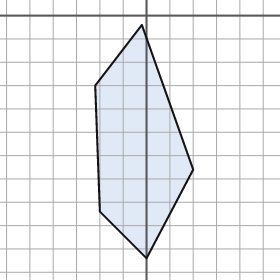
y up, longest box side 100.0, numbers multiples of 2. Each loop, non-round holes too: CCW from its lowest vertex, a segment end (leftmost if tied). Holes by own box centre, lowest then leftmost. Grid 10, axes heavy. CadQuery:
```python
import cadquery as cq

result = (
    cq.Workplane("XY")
    .moveTo(0.0, -104.0)
    .lineTo(20.0, -66.0)
    .lineTo(-2.0, -4.0)
    .lineTo(-22.0, -30.0)
    .lineTo(-20.0, -84.0)
    .close()
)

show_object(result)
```